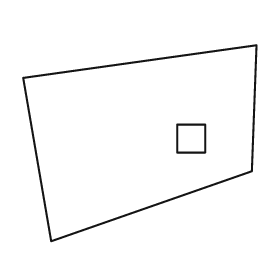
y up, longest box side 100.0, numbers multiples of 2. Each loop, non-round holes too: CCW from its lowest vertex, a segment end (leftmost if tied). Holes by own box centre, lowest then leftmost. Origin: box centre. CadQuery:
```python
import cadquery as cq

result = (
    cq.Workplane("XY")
    .moveTo(-38.0, -42.0)
    .lineTo(48.0, -12.0)
    .lineTo(50.0, 42.0)
    .lineTo(-50.0, 28.0)
    .close()
    .moveTo(16.0, -4.0)
    .lineTo(28.0, -4.0)
    .lineTo(28.0, 8.0)
    .lineTo(16.0, 8.0)
    .close()
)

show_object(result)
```